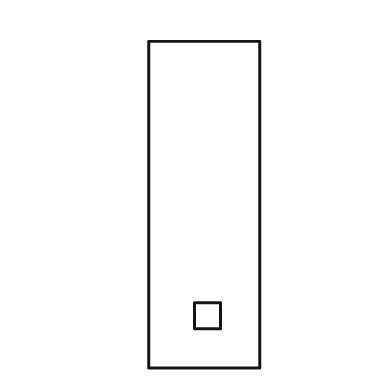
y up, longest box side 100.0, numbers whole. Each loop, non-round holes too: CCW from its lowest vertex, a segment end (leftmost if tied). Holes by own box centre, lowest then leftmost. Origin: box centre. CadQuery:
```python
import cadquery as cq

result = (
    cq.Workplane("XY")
    .moveTo(-17.0, -50.0)
    .lineTo(17.0, -50.0)
    .lineTo(17.0, 50.0)
    .lineTo(-17.0, 50.0)
    .close()
    .moveTo(-3.0, -38.0)
    .lineTo(5.0, -38.0)
    .lineTo(5.0, -30.0)
    .lineTo(-3.0, -30.0)
    .close()
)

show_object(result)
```